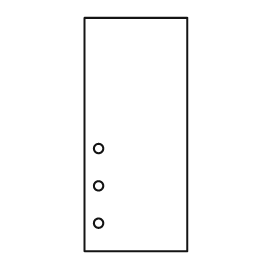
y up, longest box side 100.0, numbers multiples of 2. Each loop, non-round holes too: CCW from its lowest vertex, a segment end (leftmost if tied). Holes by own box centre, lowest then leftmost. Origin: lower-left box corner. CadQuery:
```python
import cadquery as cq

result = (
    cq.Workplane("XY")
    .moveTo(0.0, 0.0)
    .lineTo(44.0, 0.0)
    .lineTo(44.0, 100.0)
    .lineTo(0.0, 100.0)
    .close()
    .moveTo(6.0, 12.0)
    .circle(2.0)
    .moveTo(6.0, 28.0)
    .circle(2.0)
    .moveTo(6.0, 44.0)
    .circle(2.0)
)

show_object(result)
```